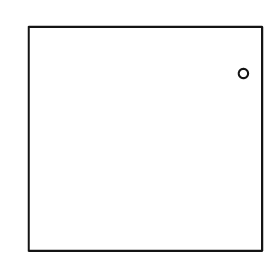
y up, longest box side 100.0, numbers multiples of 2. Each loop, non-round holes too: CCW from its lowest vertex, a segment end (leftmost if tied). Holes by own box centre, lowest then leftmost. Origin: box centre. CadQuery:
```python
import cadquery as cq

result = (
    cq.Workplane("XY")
    .moveTo(-50.0, -48.0)
    .lineTo(50.0, -48.0)
    .lineTo(50.0, 48.0)
    .lineTo(-50.0, 48.0)
    .close()
    .moveTo(42.0, 28.0)
    .circle(2.0)
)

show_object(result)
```